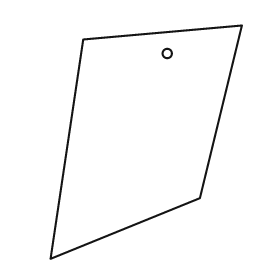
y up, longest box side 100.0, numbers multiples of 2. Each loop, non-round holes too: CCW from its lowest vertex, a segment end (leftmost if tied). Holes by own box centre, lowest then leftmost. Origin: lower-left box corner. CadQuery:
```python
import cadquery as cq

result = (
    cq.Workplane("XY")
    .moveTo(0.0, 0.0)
    .lineTo(64.0, 26.0)
    .lineTo(82.0, 100.0)
    .lineTo(14.0, 94.0)
    .close()
    .moveTo(50.0, 88.0)
    .circle(2.0)
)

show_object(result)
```